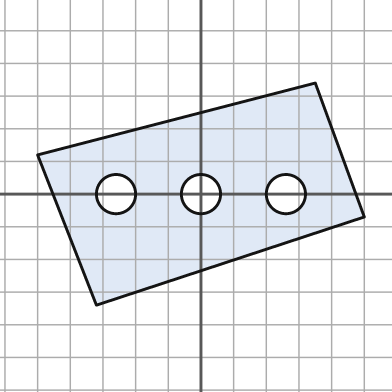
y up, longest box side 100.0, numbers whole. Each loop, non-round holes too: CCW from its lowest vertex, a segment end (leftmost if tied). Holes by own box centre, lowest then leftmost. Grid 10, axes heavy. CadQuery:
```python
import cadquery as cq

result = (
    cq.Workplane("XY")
    .moveTo(-32.0, -34.0)
    .lineTo(50.0, -7.0)
    .lineTo(35.0, 34.0)
    .lineTo(-50.0, 12.0)
    .close()
    .moveTo(-26.0, 0.0)
    .circle(6.0)
    .moveTo(0.0, 0.0)
    .circle(6.0)
    .moveTo(26.0, 0.0)
    .circle(6.0)
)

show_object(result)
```